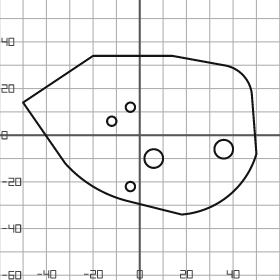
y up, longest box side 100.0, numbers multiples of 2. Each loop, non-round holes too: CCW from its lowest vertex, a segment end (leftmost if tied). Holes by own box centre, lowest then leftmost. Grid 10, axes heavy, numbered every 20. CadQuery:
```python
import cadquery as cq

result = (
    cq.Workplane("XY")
    .moveTo(18.0, -34.0)
    .threePointArc((38.0, -26.0), (50.0, -8.0))
    .lineTo(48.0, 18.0)
    .threePointArc((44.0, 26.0), (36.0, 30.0))
    .lineTo(14.0, 34.0)
    .lineTo(-20.0, 34.0)
    .lineTo(-50.0, 14.0)
    .lineTo(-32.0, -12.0)
    .threePointArc((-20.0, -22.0), (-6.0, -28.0))
    .close()
    .moveTo(-4.0, -22.0)
    .circle(2.0)
    .moveTo(6.0, -10.0)
    .circle(4.0)
    .moveTo(36.0, -6.0)
    .circle(4.0)
    .moveTo(-12.0, 6.0)
    .circle(2.0)
    .moveTo(-4.0, 12.0)
    .circle(2.0)
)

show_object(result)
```